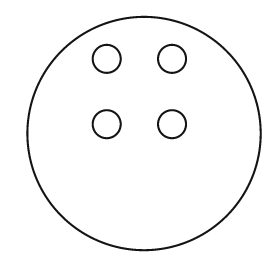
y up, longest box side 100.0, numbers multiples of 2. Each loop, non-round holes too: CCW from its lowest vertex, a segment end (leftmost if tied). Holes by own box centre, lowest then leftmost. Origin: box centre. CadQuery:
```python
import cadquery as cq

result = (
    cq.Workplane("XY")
    .moveTo(0.0, 0.0)
    .circle(50.0)
    .moveTo(-16.0, 4.0)
    .circle(6.0)
    .moveTo(12.0, 4.0)
    .circle(6.0)
    .moveTo(-16.0, 32.0)
    .circle(6.0)
    .moveTo(12.0, 32.0)
    .circle(6.0)
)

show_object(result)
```